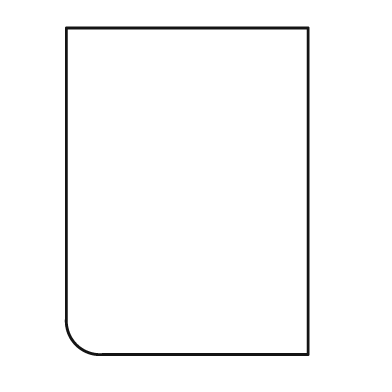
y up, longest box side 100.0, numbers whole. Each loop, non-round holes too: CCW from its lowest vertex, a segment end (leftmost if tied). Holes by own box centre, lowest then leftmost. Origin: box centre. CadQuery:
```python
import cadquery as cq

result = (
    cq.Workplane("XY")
    .moveTo(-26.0, -50.0)
    .lineTo(37.0, -50.0)
    .lineTo(37.0, 50.0)
    .lineTo(-37.0, 50.0)
    .lineTo(-37.0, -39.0)
    .threePointArc((-34.0, -47.0), (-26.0, -50.0))
    .close()
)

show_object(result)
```